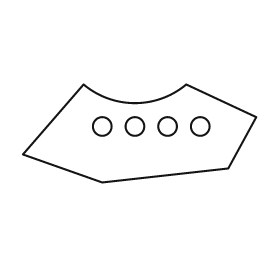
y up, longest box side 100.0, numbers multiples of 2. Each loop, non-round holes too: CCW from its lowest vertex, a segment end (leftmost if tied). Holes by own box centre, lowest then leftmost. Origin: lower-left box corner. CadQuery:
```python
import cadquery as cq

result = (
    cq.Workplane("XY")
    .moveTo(34.0, 0.0)
    .lineTo(88.0, 6.0)
    .lineTo(100.0, 28.0)
    .lineTo(70.0, 42.0)
    .threePointArc((48.0, 34.0), (26.0, 42.0))
    .lineTo(0.0, 12.0)
    .close()
    .moveTo(34.0, 24.0)
    .circle(4.0)
    .moveTo(48.0, 24.0)
    .circle(4.0)
    .moveTo(62.0, 24.0)
    .circle(4.0)
    .moveTo(76.0, 24.0)
    .circle(4.0)
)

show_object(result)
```